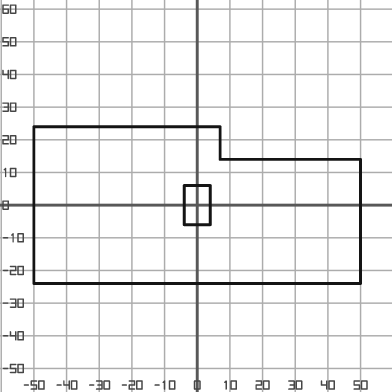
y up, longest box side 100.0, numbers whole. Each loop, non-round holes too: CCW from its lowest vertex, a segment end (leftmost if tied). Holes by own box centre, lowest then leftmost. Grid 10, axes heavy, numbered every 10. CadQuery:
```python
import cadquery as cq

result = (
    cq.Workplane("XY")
    .moveTo(-50.0, -24.0)
    .lineTo(50.0, -24.0)
    .lineTo(50.0, 14.0)
    .lineTo(7.0, 14.0)
    .lineTo(7.0, 24.0)
    .lineTo(-50.0, 24.0)
    .close()
    .moveTo(-4.0, -6.0)
    .lineTo(4.0, -6.0)
    .lineTo(4.0, 6.0)
    .lineTo(-4.0, 6.0)
    .close()
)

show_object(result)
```